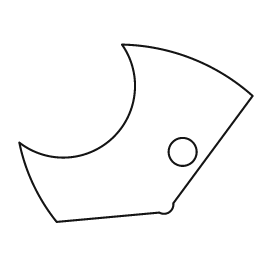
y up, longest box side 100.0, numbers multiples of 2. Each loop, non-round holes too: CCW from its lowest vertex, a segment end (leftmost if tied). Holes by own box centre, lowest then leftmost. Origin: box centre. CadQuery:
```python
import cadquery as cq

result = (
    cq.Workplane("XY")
    .moveTo(-34.0, -38.0)
    .lineTo(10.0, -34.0)
    .threePointArc((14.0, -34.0), (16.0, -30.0))
    .lineTo(50.0, 16.0)
    .threePointArc((24.0, 32.0), (-6.0, 38.0))
    .threePointArc((-10.0, -2.0), (-50.0, -4.0))
    .threePointArc((-44.0, -22.0), (-34.0, -38.0))
    .close()
    .moveTo(20.0, -8.0)
    .circle(6.0)
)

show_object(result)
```